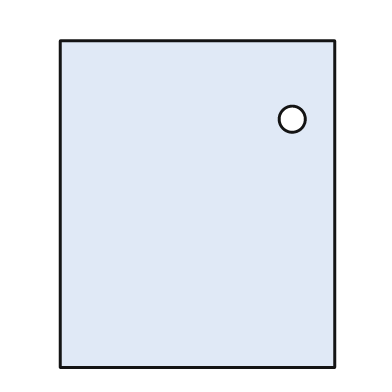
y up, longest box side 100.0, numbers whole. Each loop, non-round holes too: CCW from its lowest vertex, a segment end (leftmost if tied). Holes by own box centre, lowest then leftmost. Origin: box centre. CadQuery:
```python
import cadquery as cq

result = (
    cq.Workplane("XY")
    .moveTo(-42.0, -50.0)
    .lineTo(42.0, -50.0)
    .lineTo(42.0, 50.0)
    .lineTo(-42.0, 50.0)
    .close()
    .moveTo(29.0, 26.0)
    .circle(4.0)
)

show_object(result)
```